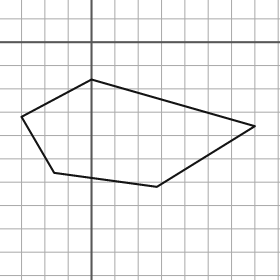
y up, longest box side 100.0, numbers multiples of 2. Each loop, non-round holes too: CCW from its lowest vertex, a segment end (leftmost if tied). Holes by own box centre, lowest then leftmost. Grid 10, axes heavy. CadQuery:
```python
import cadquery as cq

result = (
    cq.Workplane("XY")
    .moveTo(28.0, -62.0)
    .lineTo(70.0, -36.0)
    .lineTo(0.0, -16.0)
    .lineTo(-30.0, -32.0)
    .lineTo(-16.0, -56.0)
    .close()
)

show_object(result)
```